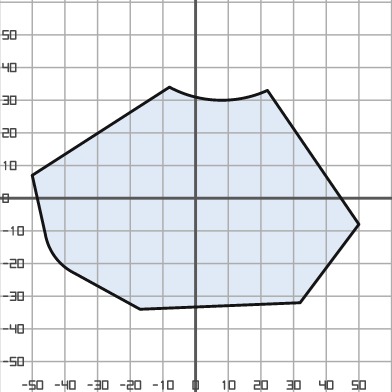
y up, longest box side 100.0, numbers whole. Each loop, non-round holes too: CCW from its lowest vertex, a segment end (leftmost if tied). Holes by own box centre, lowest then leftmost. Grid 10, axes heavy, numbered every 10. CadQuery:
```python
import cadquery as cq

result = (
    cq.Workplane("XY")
    .moveTo(-17.0, -34.0)
    .lineTo(32.0, -32.0)
    .lineTo(50.0, -8.0)
    .lineTo(22.0, 33.0)
    .threePointArc((7.0, 30.0), (-8.0, 34.0))
    .lineTo(-50.0, 7.0)
    .lineTo(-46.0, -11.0)
    .threePointArc((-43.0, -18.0), (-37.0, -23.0))
    .close()
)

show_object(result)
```